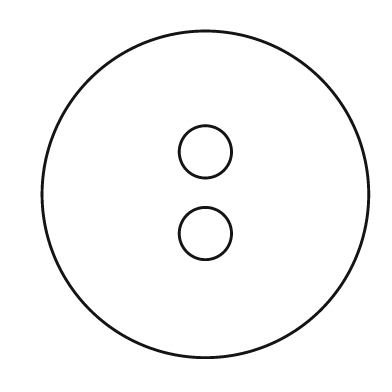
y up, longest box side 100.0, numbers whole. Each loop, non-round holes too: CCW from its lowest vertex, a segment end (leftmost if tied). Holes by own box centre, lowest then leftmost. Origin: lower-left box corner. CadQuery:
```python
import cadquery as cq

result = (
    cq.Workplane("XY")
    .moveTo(50.0, 50.0)
    .circle(50.0)
    .moveTo(50.0, 38.0)
    .circle(8.0)
    .moveTo(50.0, 63.0)
    .circle(8.0)
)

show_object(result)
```